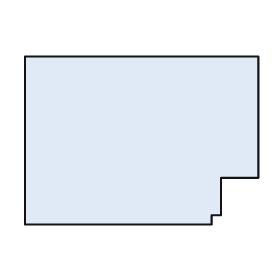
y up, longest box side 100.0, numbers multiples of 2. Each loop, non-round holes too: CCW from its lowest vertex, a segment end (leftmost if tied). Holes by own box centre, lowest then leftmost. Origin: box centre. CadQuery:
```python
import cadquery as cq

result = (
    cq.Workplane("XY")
    .moveTo(-50.0, -36.0)
    .lineTo(30.0, -36.0)
    .lineTo(30.0, -32.0)
    .lineTo(34.0, -32.0)
    .lineTo(34.0, -16.0)
    .lineTo(50.0, -16.0)
    .lineTo(50.0, 36.0)
    .lineTo(-50.0, 36.0)
    .close()
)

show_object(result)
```